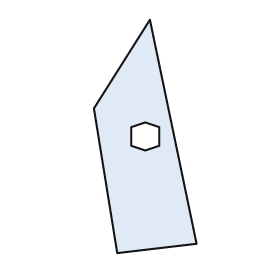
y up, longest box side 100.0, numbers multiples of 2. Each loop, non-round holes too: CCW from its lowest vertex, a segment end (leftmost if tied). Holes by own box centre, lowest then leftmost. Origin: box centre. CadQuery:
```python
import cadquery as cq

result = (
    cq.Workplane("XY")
    .moveTo(-12.0, -50.0)
    .lineTo(22.0, -46.0)
    .lineTo(2.0, 50.0)
    .lineTo(-22.0, 12.0)
    .close()
    .moveTo(0.0, -6.0)
    .lineTo(6.0, -4.0)
    .lineTo(6.0, 4.0)
    .lineTo(0.0, 6.0)
    .lineTo(-6.0, 4.0)
    .lineTo(-6.0, -4.0)
    .close()
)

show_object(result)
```